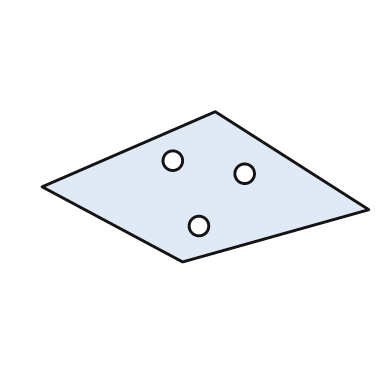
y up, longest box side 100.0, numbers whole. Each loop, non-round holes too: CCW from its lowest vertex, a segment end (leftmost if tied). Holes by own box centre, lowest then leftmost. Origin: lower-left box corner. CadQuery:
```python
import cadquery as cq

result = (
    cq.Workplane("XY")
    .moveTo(43.0, 0.0)
    .lineTo(100.0, 16.0)
    .lineTo(53.0, 46.0)
    .lineTo(0.0, 23.0)
    .close()
    .moveTo(48.0, 11.0)
    .circle(3.0)
    .moveTo(62.0, 27.0)
    .circle(3.0)
    .moveTo(40.0, 31.0)
    .circle(3.0)
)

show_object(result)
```